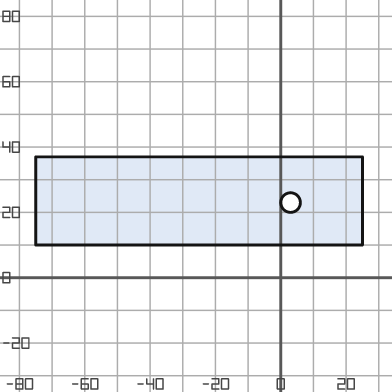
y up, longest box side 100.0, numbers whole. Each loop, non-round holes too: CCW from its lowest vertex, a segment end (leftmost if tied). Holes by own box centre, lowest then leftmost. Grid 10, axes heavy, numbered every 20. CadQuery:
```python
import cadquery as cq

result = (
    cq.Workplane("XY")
    .moveTo(-75.0, 10.0)
    .lineTo(25.0, 10.0)
    .lineTo(25.0, 37.0)
    .lineTo(-75.0, 37.0)
    .close()
    .moveTo(3.0, 23.0)
    .circle(3.0)
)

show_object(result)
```